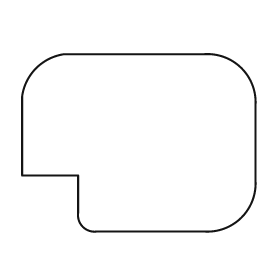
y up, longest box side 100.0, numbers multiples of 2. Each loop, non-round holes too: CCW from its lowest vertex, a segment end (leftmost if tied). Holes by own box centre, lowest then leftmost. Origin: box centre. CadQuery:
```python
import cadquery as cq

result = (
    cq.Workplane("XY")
    .moveTo(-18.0, -38.0)
    .lineTo(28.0, -38.0)
    .threePointArc((44.0, -32.0), (50.0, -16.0))
    .lineTo(50.0, 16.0)
    .threePointArc((44.0, 32.0), (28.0, 38.0))
    .lineTo(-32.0, 38.0)
    .threePointArc((-44.0, 32.0), (-50.0, 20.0))
    .lineTo(-50.0, -14.0)
    .lineTo(-26.0, -14.0)
    .lineTo(-26.0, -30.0)
    .threePointArc((-24.0, -36.0), (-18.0, -38.0))
    .close()
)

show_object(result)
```